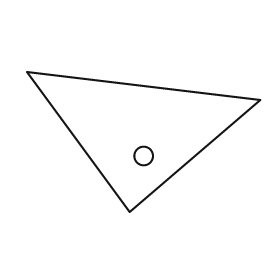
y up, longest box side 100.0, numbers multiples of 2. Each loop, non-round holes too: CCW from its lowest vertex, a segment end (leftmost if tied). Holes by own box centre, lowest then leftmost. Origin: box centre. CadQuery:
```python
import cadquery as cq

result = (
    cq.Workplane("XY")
    .moveTo(-6.0, -30.0)
    .lineTo(50.0, 18.0)
    .lineTo(-50.0, 30.0)
    .close()
    .moveTo(0.0, -6.0)
    .circle(4.0)
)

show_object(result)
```